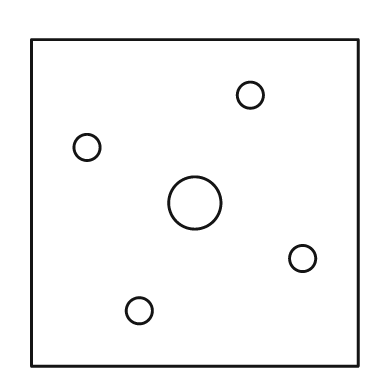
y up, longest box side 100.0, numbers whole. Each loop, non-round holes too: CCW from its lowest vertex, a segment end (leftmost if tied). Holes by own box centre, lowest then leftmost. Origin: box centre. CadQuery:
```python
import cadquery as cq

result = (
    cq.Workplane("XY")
    .moveTo(-50.0, -50.0)
    .lineTo(50.0, -50.0)
    .lineTo(50.0, 50.0)
    .lineTo(-50.0, 50.0)
    .close()
    .moveTo(-17.0, -33.0)
    .circle(4.0)
    .moveTo(33.0, -17.0)
    .circle(4.0)
    .moveTo(0.0, 0.0)
    .circle(8.0)
    .moveTo(-33.0, 17.0)
    .circle(4.0)
    .moveTo(17.0, 33.0)
    .circle(4.0)
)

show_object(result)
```